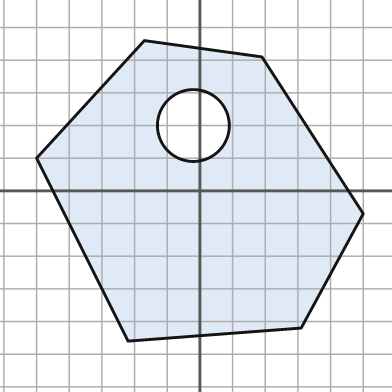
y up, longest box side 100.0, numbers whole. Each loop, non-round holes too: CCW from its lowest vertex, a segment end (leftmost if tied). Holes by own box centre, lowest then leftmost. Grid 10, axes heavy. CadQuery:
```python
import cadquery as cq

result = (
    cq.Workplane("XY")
    .moveTo(-22.0, -46.0)
    .lineTo(31.0, -42.0)
    .lineTo(50.0, -7.0)
    .lineTo(19.0, 41.0)
    .lineTo(-17.0, 46.0)
    .lineTo(-50.0, 10.0)
    .close()
    .moveTo(-2.0, 20.0)
    .circle(11.0)
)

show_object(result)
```